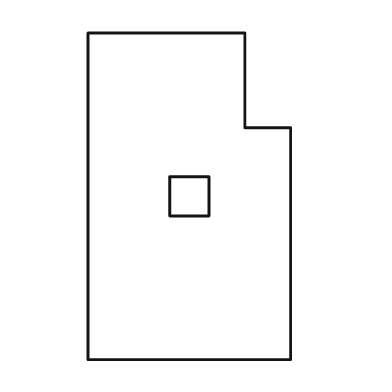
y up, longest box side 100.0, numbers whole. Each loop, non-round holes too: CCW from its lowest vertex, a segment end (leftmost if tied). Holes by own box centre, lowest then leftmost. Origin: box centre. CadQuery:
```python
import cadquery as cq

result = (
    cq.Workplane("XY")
    .moveTo(-31.0, -50.0)
    .lineTo(31.0, -50.0)
    .lineTo(31.0, 21.0)
    .lineTo(17.0, 21.0)
    .lineTo(17.0, 50.0)
    .lineTo(-31.0, 50.0)
    .close()
    .moveTo(-6.0, -6.0)
    .lineTo(6.0, -6.0)
    .lineTo(6.0, 6.0)
    .lineTo(-6.0, 6.0)
    .close()
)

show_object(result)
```